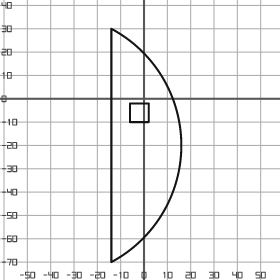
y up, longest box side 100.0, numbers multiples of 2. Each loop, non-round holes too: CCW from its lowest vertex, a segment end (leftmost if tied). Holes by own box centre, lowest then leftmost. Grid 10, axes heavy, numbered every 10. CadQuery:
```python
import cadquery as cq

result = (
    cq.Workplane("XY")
    .moveTo(-14.0, -70.0)
    .threePointArc((16.0, -20.0), (-14.0, 30.0))
    .close()
    .moveTo(-6.0, -10.0)
    .lineTo(2.0, -10.0)
    .lineTo(2.0, -2.0)
    .lineTo(-6.0, -2.0)
    .close()
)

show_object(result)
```